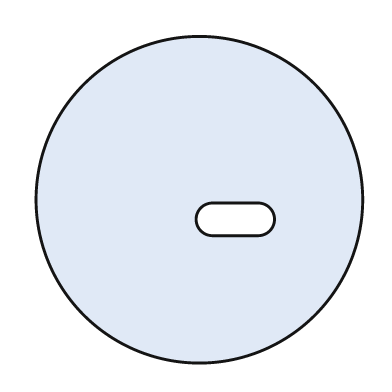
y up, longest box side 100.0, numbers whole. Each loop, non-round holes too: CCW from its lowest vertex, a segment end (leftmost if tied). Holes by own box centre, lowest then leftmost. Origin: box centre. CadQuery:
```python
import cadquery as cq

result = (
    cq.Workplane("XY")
    .moveTo(0.0, 0.0)
    .circle(50.0)
    .moveTo(4.0, -11.0)
    .lineTo(18.0, -11.0)
    .threePointArc((23.0, -6.0), (18.0, -1.0))
    .lineTo(4.0, -1.0)
    .threePointArc((-1.0, -6.0), (4.0, -11.0))
    .close()
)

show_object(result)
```